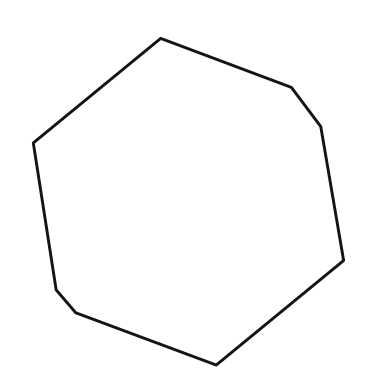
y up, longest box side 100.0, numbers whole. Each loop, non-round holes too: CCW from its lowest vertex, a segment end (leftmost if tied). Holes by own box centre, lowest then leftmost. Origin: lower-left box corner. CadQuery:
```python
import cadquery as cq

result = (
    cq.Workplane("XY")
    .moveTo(56.0, 0.0)
    .lineTo(95.0, 32.0)
    .lineTo(88.0, 73.0)
    .lineTo(79.0, 85.0)
    .lineTo(39.0, 100.0)
    .lineTo(0.0, 68.0)
    .lineTo(7.0, 23.0)
    .lineTo(13.0, 16.0)
    .close()
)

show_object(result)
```